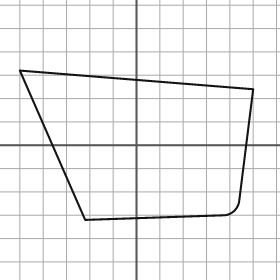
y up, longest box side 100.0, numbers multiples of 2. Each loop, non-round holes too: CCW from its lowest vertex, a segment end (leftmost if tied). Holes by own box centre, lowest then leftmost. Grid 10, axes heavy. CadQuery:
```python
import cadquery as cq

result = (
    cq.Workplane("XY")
    .moveTo(-22.0, -32.0)
    .lineTo(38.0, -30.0)
    .threePointArc((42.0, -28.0), (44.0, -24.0))
    .lineTo(50.0, 24.0)
    .lineTo(-50.0, 32.0)
    .close()
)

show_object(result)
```